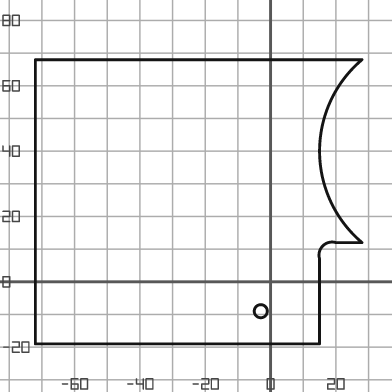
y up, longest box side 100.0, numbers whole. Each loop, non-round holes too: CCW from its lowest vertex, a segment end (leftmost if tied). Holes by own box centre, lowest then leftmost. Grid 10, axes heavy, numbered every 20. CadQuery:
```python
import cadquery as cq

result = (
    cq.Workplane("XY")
    .moveTo(-72.0, -19.0)
    .lineTo(15.0, -19.0)
    .lineTo(15.0, 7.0)
    .threePointArc((16.0, 11.0), (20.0, 12.0))
    .lineTo(28.0, 12.0)
    .threePointArc((15.0, 40.0), (28.0, 68.0))
    .lineTo(-72.0, 68.0)
    .close()
    .moveTo(-3.0, -9.0)
    .circle(2.0)
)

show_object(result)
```